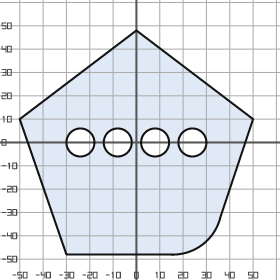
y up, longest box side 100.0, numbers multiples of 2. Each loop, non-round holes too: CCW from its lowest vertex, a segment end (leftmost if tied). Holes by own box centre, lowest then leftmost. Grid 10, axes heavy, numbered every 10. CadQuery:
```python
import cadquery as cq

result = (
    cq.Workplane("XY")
    .moveTo(-30.0, -48.0)
    .lineTo(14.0, -48.0)
    .threePointArc((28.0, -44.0), (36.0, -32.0))
    .lineTo(50.0, 10.0)
    .lineTo(0.0, 48.0)
    .lineTo(-50.0, 10.0)
    .close()
    .moveTo(-24.0, 0.0)
    .circle(6.0)
    .moveTo(-8.0, 0.0)
    .circle(6.0)
    .moveTo(8.0, 0.0)
    .circle(6.0)
    .moveTo(24.0, 0.0)
    .circle(6.0)
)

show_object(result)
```